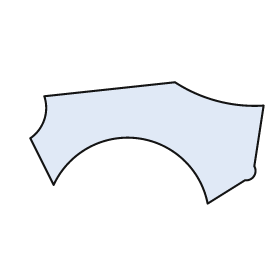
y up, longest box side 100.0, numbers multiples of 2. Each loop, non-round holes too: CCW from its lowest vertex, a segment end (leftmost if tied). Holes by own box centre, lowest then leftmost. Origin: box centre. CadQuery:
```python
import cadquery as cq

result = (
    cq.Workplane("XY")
    .moveTo(26.0, -26.0)
    .lineTo(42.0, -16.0)
    .threePointArc((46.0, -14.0), (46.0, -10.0))
    .lineTo(50.0, 16.0)
    .threePointArc((30.0, 18.0), (12.0, 26.0))
    .lineTo(-44.0, 20.0)
    .threePointArc((-44.0, 10.0), (-50.0, 2.0))
    .lineTo(-40.0, -18.0)
    .threePointArc((-4.0, 2.0), (26.0, -26.0))
    .close()
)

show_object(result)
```